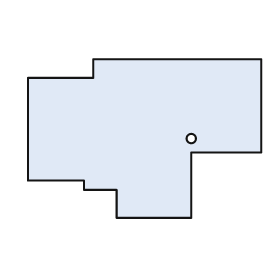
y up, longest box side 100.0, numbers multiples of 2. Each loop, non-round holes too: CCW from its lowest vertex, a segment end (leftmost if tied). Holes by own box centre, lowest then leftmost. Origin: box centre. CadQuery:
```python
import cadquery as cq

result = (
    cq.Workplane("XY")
    .moveTo(-12.0, -34.0)
    .lineTo(20.0, -34.0)
    .lineTo(20.0, -6.0)
    .lineTo(50.0, -6.0)
    .lineTo(50.0, 34.0)
    .lineTo(-22.0, 34.0)
    .lineTo(-22.0, 26.0)
    .lineTo(-50.0, 26.0)
    .lineTo(-50.0, -18.0)
    .lineTo(-26.0, -18.0)
    .lineTo(-26.0, -22.0)
    .lineTo(-12.0, -22.0)
    .close()
    .moveTo(20.0, 0.0)
    .circle(2.0)
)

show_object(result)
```